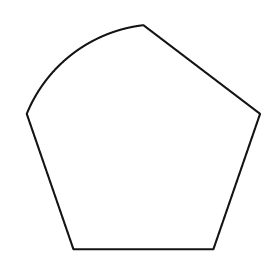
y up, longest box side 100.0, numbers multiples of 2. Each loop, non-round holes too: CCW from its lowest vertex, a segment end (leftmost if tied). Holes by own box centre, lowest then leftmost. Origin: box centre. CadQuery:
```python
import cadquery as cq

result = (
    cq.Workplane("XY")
    .moveTo(-30.0, -48.0)
    .lineTo(30.0, -48.0)
    .lineTo(50.0, 10.0)
    .lineTo(0.0, 48.0)
    .threePointArc((-30.0, 36.0), (-50.0, 10.0))
    .close()
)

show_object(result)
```